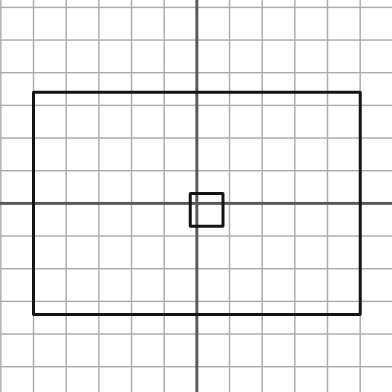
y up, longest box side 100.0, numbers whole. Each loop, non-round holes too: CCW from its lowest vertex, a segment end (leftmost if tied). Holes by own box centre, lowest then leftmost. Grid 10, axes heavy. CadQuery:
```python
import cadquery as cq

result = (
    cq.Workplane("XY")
    .moveTo(-50.0, -34.0)
    .lineTo(50.0, -34.0)
    .lineTo(50.0, 34.0)
    .lineTo(-50.0, 34.0)
    .close()
    .moveTo(-2.0, -7.0)
    .lineTo(8.0, -7.0)
    .lineTo(8.0, 3.0)
    .lineTo(-2.0, 3.0)
    .close()
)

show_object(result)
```